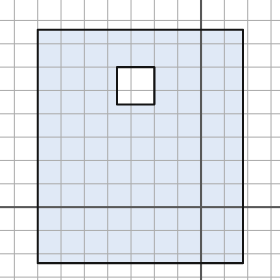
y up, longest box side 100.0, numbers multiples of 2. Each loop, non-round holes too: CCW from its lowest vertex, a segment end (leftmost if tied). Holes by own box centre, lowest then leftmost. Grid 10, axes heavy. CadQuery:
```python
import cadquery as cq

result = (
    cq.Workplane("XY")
    .moveTo(-70.0, -24.0)
    .lineTo(18.0, -24.0)
    .lineTo(18.0, 76.0)
    .lineTo(-70.0, 76.0)
    .close()
    .moveTo(-36.0, 44.0)
    .lineTo(-20.0, 44.0)
    .lineTo(-20.0, 60.0)
    .lineTo(-36.0, 60.0)
    .close()
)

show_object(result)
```